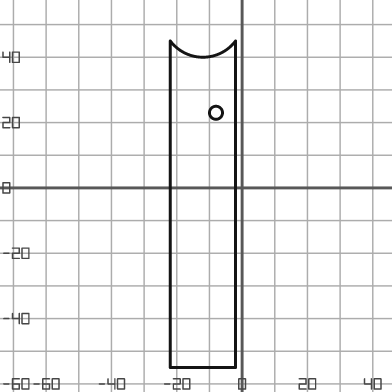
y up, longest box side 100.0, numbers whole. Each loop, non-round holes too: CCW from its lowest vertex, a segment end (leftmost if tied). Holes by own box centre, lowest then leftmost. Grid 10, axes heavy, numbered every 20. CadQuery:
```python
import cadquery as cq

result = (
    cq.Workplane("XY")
    .moveTo(-22.0, -55.0)
    .lineTo(-2.0, -55.0)
    .lineTo(-2.0, 45.0)
    .threePointArc((-12.0, 40.0), (-22.0, 45.0))
    .close()
    .moveTo(-8.0, 23.0)
    .circle(2.0)
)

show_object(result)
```